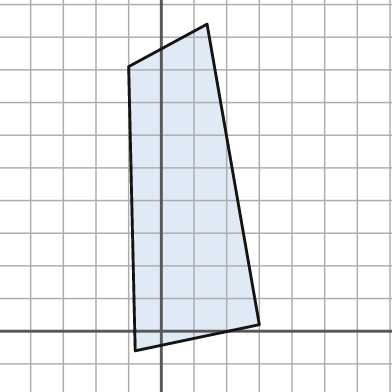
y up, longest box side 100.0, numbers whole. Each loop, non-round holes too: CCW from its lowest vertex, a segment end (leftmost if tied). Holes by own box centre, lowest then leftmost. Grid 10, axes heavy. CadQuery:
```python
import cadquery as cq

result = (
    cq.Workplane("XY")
    .moveTo(-8.0, -6.0)
    .lineTo(30.0, 2.0)
    .lineTo(14.0, 94.0)
    .lineTo(-10.0, 81.0)
    .close()
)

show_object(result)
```